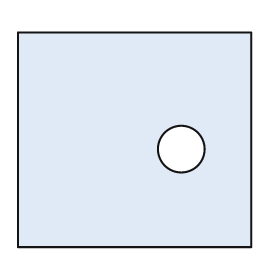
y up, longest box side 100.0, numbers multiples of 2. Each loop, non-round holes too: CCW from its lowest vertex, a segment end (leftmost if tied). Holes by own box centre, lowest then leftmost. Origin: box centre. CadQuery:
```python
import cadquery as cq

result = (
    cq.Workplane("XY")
    .moveTo(-50.0, -46.0)
    .lineTo(50.0, -46.0)
    .lineTo(50.0, 46.0)
    .lineTo(-50.0, 46.0)
    .close()
    .moveTo(20.0, -4.0)
    .circle(10.0)
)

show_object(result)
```